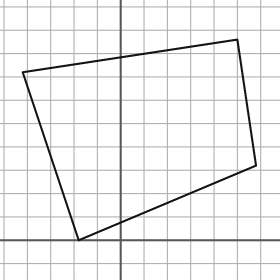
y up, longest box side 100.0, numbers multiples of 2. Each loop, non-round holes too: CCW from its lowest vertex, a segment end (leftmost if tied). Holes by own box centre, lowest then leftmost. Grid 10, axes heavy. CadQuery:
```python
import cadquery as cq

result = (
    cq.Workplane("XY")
    .moveTo(-18.0, 0.0)
    .lineTo(58.0, 32.0)
    .lineTo(50.0, 86.0)
    .lineTo(-42.0, 72.0)
    .close()
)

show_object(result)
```